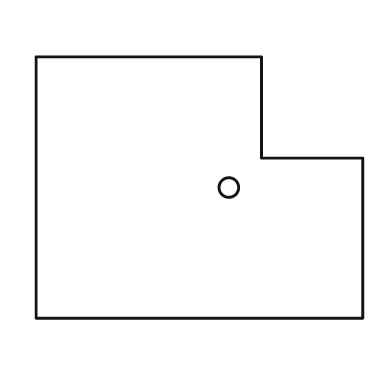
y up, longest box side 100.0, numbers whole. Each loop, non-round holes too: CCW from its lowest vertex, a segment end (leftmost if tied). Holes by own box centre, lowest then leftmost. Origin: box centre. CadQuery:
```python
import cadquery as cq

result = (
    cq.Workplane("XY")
    .moveTo(-50.0, -40.0)
    .lineTo(50.0, -40.0)
    .lineTo(50.0, 9.0)
    .lineTo(19.0, 9.0)
    .lineTo(19.0, 40.0)
    .lineTo(-50.0, 40.0)
    .close()
    .moveTo(9.0, 0.0)
    .circle(3.0)
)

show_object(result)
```